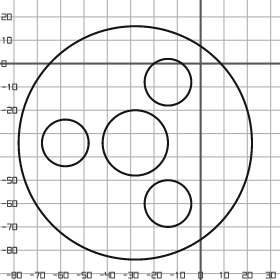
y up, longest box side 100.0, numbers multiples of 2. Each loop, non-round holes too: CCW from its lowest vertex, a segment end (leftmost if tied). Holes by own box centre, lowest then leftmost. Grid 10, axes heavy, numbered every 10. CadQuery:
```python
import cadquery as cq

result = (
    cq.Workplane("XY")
    .moveTo(-28.0, -34.0)
    .circle(50.0)
    .moveTo(-14.0, -60.0)
    .circle(10.0)
    .moveTo(-58.0, -34.0)
    .circle(10.0)
    .moveTo(-28.0, -34.0)
    .circle(14.0)
    .moveTo(-14.0, -8.0)
    .circle(10.0)
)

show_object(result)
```